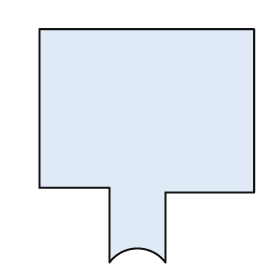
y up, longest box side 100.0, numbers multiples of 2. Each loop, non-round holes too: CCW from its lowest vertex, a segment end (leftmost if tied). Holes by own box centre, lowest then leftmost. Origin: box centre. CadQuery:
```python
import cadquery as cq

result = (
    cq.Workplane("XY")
    .moveTo(-16.0, -50.0)
    .threePointArc((-4.0, -44.0), (8.0, -50.0))
    .lineTo(8.0, -20.0)
    .lineTo(46.0, -20.0)
    .lineTo(46.0, 50.0)
    .lineTo(-46.0, 50.0)
    .lineTo(-46.0, -18.0)
    .lineTo(-16.0, -18.0)
    .close()
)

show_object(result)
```